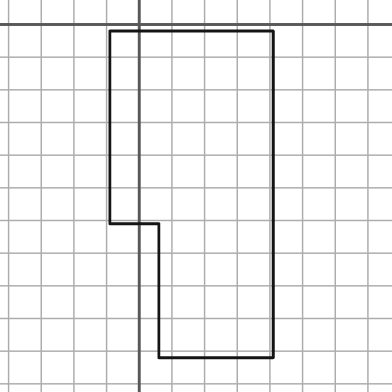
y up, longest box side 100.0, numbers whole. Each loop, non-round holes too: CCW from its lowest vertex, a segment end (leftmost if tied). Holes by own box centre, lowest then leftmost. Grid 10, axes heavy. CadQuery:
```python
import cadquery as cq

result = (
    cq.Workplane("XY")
    .moveTo(6.0, -102.0)
    .lineTo(41.0, -102.0)
    .lineTo(41.0, -2.0)
    .lineTo(-9.0, -2.0)
    .lineTo(-9.0, -61.0)
    .lineTo(6.0, -61.0)
    .close()
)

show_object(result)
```